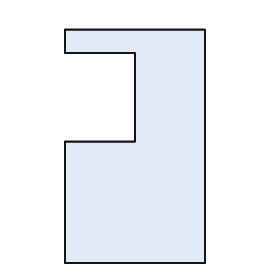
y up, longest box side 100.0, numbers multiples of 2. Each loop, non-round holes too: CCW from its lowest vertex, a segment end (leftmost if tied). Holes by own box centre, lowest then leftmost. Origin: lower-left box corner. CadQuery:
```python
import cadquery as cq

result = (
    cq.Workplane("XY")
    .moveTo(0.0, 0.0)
    .lineTo(60.0, 0.0)
    .lineTo(60.0, 100.0)
    .lineTo(0.0, 100.0)
    .lineTo(0.0, 90.0)
    .lineTo(30.0, 90.0)
    .lineTo(30.0, 52.0)
    .lineTo(0.0, 52.0)
    .close()
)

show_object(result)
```